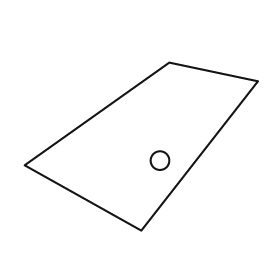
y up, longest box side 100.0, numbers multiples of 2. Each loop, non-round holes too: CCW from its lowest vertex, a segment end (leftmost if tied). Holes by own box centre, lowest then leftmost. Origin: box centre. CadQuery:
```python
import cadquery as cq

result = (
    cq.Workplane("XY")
    .moveTo(0.0, -36.0)
    .lineTo(50.0, 28.0)
    .lineTo(12.0, 36.0)
    .lineTo(-50.0, -8.0)
    .close()
    .moveTo(8.0, -6.0)
    .circle(4.0)
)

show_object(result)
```